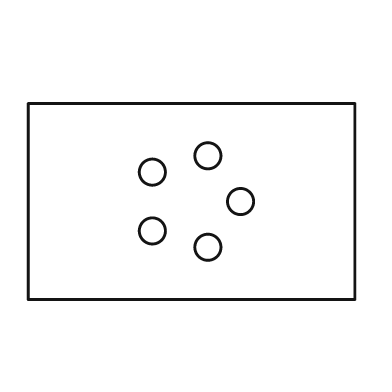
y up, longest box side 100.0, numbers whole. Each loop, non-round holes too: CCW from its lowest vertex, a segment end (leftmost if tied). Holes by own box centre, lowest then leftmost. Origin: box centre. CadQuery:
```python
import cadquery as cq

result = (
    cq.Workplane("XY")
    .moveTo(-50.0, -30.0)
    .lineTo(50.0, -30.0)
    .lineTo(50.0, 30.0)
    .lineTo(-50.0, 30.0)
    .close()
    .moveTo(5.0, -14.0)
    .circle(4.0)
    .moveTo(-12.0, -9.0)
    .circle(4.0)
    .moveTo(15.0, 0.0)
    .circle(4.0)
    .moveTo(-12.0, 9.0)
    .circle(4.0)
    .moveTo(5.0, 14.0)
    .circle(4.0)
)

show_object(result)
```